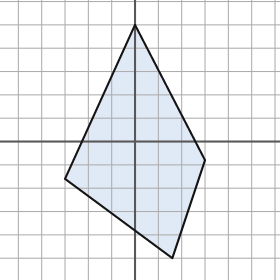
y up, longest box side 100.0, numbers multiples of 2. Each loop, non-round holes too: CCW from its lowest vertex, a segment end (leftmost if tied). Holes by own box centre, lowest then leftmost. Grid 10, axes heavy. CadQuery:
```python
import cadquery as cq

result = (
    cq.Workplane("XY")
    .moveTo(16.0, -50.0)
    .lineTo(30.0, -8.0)
    .lineTo(0.0, 50.0)
    .lineTo(-30.0, -16.0)
    .close()
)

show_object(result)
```